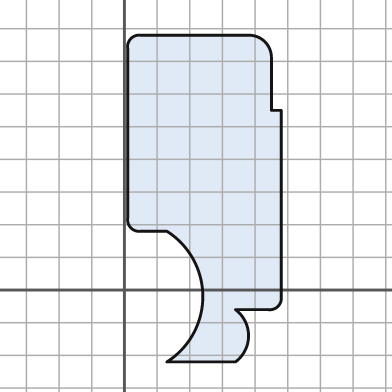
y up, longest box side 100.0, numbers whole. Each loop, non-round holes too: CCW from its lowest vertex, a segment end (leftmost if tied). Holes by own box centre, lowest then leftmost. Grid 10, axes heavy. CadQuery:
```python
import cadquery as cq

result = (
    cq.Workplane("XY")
    .moveTo(13.0, -22.0)
    .lineTo(34.0, -22.0)
    .threePointArc((38.0, -14.0), (34.0, -6.0))
    .lineTo(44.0, -6.0)
    .threePointArc((47.0, -5.0), (48.0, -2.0))
    .lineTo(48.0, 55.0)
    .lineTo(45.0, 55.0)
    .lineTo(45.0, 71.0)
    .threePointArc((43.0, 76.0), (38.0, 78.0))
    .lineTo(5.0, 78.0)
    .threePointArc((2.0, 77.0), (1.0, 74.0))
    .lineTo(1.0, 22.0)
    .threePointArc((2.0, 19.0), (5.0, 18.0))
    .lineTo(13.0, 18.0)
    .threePointArc((24.0, -2.0), (13.0, -22.0))
    .close()
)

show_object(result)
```